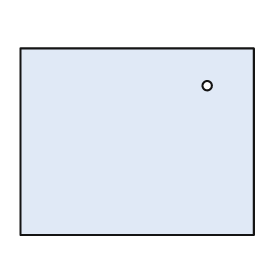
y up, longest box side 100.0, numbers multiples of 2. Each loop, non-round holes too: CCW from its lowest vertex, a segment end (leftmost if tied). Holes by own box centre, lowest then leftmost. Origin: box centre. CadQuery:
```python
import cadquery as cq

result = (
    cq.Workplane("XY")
    .moveTo(-50.0, -40.0)
    .lineTo(50.0, -40.0)
    .lineTo(50.0, 40.0)
    .lineTo(-50.0, 40.0)
    .close()
    .moveTo(30.0, 24.0)
    .circle(2.0)
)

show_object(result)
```